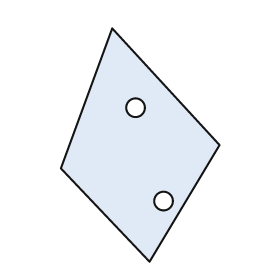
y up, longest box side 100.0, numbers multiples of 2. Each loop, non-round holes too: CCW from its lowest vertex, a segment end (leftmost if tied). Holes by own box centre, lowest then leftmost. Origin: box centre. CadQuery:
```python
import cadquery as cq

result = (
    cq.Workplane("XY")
    .moveTo(4.0, -50.0)
    .lineTo(34.0, 0.0)
    .lineTo(-12.0, 50.0)
    .lineTo(-34.0, -10.0)
    .close()
    .moveTo(10.0, -24.0)
    .circle(4.0)
    .moveTo(-2.0, 16.0)
    .circle(4.0)
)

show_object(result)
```